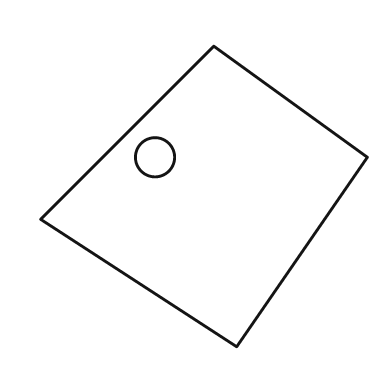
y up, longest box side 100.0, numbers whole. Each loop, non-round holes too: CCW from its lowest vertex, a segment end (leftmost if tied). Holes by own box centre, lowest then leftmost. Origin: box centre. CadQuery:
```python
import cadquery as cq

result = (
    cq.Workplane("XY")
    .moveTo(10.0, -46.0)
    .lineTo(50.0, 12.0)
    .lineTo(3.0, 46.0)
    .lineTo(-50.0, -7.0)
    .close()
    .moveTo(-15.0, 12.0)
    .circle(6.0)
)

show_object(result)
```